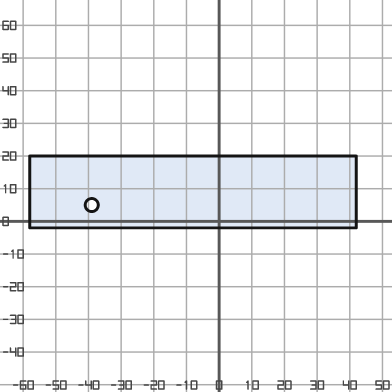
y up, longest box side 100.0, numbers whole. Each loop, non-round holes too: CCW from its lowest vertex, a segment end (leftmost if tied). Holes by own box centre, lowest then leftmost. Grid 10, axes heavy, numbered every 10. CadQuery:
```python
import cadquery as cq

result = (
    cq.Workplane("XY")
    .moveTo(-58.0, -2.0)
    .lineTo(42.0, -2.0)
    .lineTo(42.0, 20.0)
    .lineTo(-58.0, 20.0)
    .close()
    .moveTo(-39.0, 5.0)
    .circle(2.0)
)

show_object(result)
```